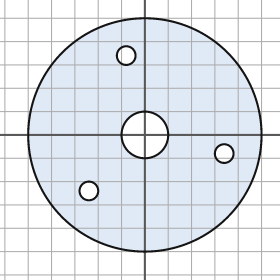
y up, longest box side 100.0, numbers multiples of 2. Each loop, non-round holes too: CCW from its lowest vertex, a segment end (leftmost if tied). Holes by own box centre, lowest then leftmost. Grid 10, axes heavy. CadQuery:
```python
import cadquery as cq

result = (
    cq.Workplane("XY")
    .moveTo(0.0, 0.0)
    .circle(50.0)
    .moveTo(-24.0, -24.0)
    .circle(4.0)
    .moveTo(34.0, -8.0)
    .circle(4.0)
    .moveTo(0.0, 0.0)
    .circle(10.0)
    .moveTo(-8.0, 34.0)
    .circle(4.0)
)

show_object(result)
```